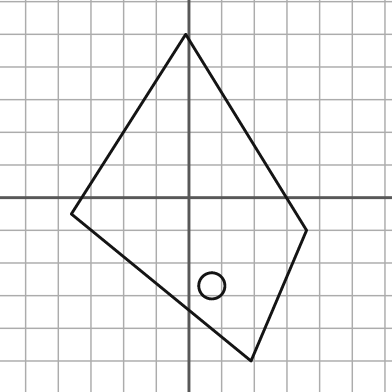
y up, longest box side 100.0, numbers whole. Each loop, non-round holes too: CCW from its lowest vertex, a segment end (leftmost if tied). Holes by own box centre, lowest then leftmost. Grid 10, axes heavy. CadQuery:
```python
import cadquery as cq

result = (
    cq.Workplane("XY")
    .moveTo(19.0, -50.0)
    .lineTo(36.0, -10.0)
    .lineTo(-1.0, 50.0)
    .lineTo(-36.0, -5.0)
    .close()
    .moveTo(7.0, -27.0)
    .circle(4.0)
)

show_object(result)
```